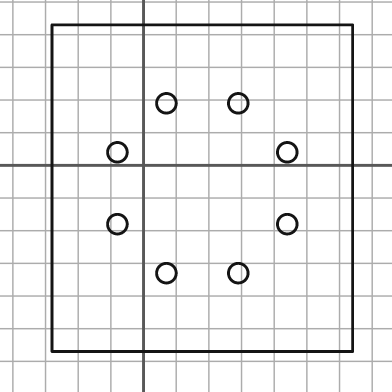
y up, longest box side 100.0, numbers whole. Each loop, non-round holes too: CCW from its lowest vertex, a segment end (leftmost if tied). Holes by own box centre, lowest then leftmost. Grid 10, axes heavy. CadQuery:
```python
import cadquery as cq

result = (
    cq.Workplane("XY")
    .moveTo(-28.0, -57.0)
    .lineTo(64.0, -57.0)
    .lineTo(64.0, 43.0)
    .lineTo(-28.0, 43.0)
    .close()
    .moveTo(7.0, -33.0)
    .circle(3.0)
    .moveTo(29.0, -33.0)
    .circle(3.0)
    .moveTo(-8.0, -18.0)
    .circle(3.0)
    .moveTo(44.0, -18.0)
    .circle(3.0)
    .moveTo(-8.0, 4.0)
    .circle(3.0)
    .moveTo(44.0, 4.0)
    .circle(3.0)
    .moveTo(7.0, 19.0)
    .circle(3.0)
    .moveTo(29.0, 19.0)
    .circle(3.0)
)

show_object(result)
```